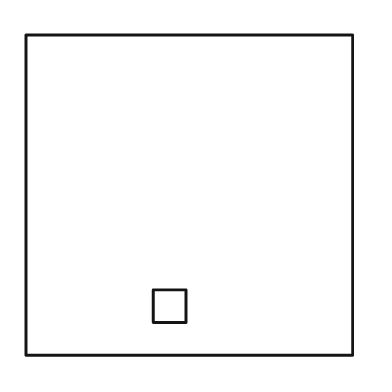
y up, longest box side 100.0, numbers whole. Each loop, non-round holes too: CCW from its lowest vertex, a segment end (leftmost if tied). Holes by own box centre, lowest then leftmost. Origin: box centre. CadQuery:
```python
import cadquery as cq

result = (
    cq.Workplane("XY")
    .moveTo(-50.0, -49.0)
    .lineTo(50.0, -49.0)
    .lineTo(50.0, 49.0)
    .lineTo(-50.0, 49.0)
    .close()
    .moveTo(-11.0, -39.0)
    .lineTo(-1.0, -39.0)
    .lineTo(-1.0, -29.0)
    .lineTo(-11.0, -29.0)
    .close()
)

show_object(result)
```